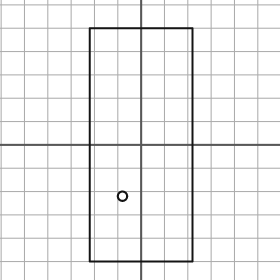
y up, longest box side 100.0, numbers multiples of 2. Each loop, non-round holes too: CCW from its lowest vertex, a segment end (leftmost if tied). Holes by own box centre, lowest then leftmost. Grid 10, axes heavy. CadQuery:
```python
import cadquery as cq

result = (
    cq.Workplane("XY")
    .moveTo(-22.0, -50.0)
    .lineTo(22.0, -50.0)
    .lineTo(22.0, 50.0)
    .lineTo(-22.0, 50.0)
    .close()
    .moveTo(-8.0, -22.0)
    .circle(2.0)
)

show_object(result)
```